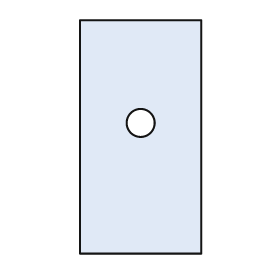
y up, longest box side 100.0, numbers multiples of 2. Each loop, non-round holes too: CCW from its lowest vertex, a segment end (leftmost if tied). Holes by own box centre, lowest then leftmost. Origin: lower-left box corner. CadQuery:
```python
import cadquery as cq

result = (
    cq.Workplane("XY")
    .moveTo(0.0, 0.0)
    .lineTo(52.0, 0.0)
    .lineTo(52.0, 100.0)
    .lineTo(0.0, 100.0)
    .close()
    .moveTo(26.0, 56.0)
    .circle(6.0)
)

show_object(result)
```